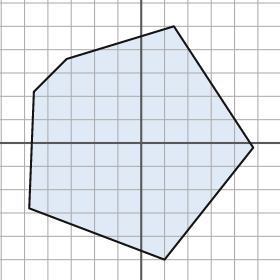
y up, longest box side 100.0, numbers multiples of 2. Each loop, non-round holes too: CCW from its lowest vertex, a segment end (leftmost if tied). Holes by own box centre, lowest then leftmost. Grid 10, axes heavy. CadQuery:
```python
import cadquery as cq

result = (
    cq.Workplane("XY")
    .moveTo(10.0, -50.0)
    .lineTo(48.0, -2.0)
    .lineTo(14.0, 50.0)
    .lineTo(-32.0, 36.0)
    .lineTo(-46.0, 22.0)
    .lineTo(-48.0, -28.0)
    .close()
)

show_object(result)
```